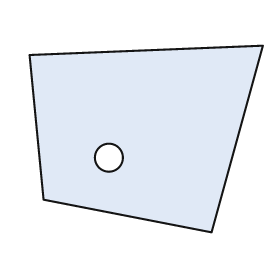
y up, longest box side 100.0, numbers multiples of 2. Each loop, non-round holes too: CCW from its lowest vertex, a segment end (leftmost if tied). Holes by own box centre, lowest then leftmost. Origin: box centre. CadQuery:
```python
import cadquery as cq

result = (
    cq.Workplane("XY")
    .moveTo(28.0, -40.0)
    .lineTo(50.0, 40.0)
    .lineTo(-50.0, 36.0)
    .lineTo(-44.0, -26.0)
    .close()
    .moveTo(-16.0, -8.0)
    .circle(6.0)
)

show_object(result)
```